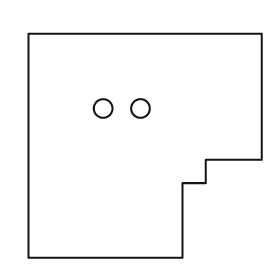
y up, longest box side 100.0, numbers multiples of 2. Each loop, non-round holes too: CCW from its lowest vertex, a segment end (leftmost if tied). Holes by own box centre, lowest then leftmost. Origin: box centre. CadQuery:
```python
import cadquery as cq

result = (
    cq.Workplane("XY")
    .moveTo(-50.0, -48.0)
    .lineTo(16.0, -48.0)
    .lineTo(16.0, -16.0)
    .lineTo(26.0, -16.0)
    .lineTo(26.0, -6.0)
    .lineTo(50.0, -6.0)
    .lineTo(50.0, 48.0)
    .lineTo(-50.0, 48.0)
    .close()
    .moveTo(-18.0, 16.0)
    .circle(4.0)
    .moveTo(-2.0, 16.0)
    .circle(4.0)
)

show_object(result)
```